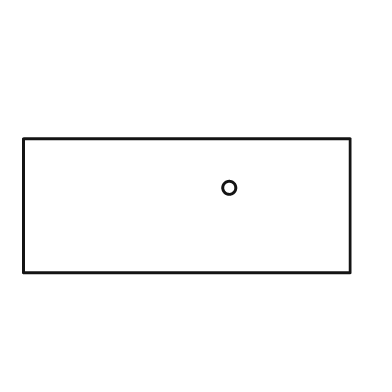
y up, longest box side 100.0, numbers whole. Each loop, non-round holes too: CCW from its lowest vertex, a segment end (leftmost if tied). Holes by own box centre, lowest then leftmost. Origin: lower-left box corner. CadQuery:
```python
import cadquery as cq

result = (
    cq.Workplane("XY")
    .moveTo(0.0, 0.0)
    .lineTo(100.0, 0.0)
    .lineTo(100.0, 41.0)
    .lineTo(0.0, 41.0)
    .close()
    .moveTo(63.0, 26.0)
    .circle(2.0)
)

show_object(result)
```